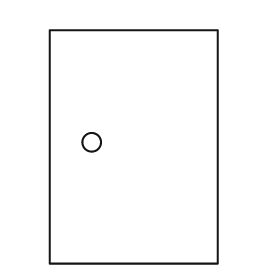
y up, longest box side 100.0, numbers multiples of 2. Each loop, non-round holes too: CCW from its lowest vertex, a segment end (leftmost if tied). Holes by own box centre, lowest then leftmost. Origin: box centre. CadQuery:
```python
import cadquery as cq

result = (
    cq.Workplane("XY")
    .moveTo(-36.0, -50.0)
    .lineTo(36.0, -50.0)
    .lineTo(36.0, 50.0)
    .lineTo(-36.0, 50.0)
    .close()
    .moveTo(-18.0, 2.0)
    .circle(4.0)
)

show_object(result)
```